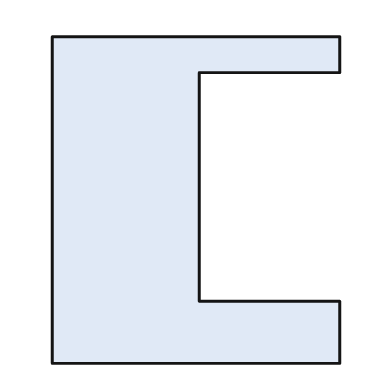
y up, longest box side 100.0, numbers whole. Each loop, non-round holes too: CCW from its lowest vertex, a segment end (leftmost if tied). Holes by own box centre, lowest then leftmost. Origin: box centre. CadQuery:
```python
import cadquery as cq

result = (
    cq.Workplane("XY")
    .moveTo(-44.0, -50.0)
    .lineTo(44.0, -50.0)
    .lineTo(44.0, -31.0)
    .lineTo(1.0, -31.0)
    .lineTo(1.0, 39.0)
    .lineTo(44.0, 39.0)
    .lineTo(44.0, 50.0)
    .lineTo(-44.0, 50.0)
    .close()
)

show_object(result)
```